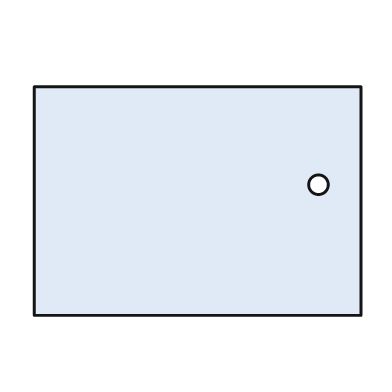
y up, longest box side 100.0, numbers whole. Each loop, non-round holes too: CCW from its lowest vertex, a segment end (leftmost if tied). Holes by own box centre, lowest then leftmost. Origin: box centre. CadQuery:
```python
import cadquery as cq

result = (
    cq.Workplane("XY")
    .moveTo(-50.0, -35.0)
    .lineTo(50.0, -35.0)
    .lineTo(50.0, 35.0)
    .lineTo(-50.0, 35.0)
    .close()
    .moveTo(37.0, 5.0)
    .circle(3.0)
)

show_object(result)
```